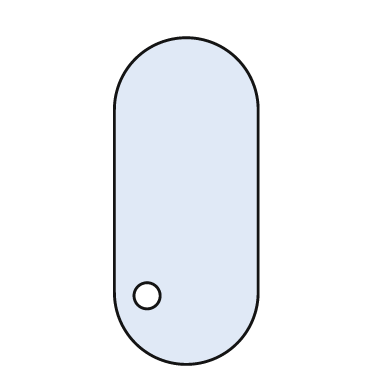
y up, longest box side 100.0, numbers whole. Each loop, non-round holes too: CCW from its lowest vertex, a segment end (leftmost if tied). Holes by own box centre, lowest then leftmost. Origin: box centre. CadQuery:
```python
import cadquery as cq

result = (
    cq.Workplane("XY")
    .moveTo(-22.0, -28.0)
    .threePointArc((0.0, -50.0), (22.0, -28.0))
    .lineTo(22.0, 28.0)
    .threePointArc((0.0, 50.0), (-22.0, 28.0))
    .close()
    .moveTo(-12.0, -29.0)
    .circle(4.0)
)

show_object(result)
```